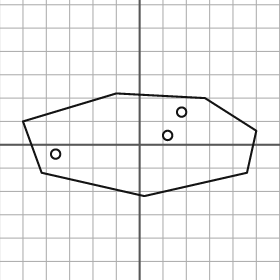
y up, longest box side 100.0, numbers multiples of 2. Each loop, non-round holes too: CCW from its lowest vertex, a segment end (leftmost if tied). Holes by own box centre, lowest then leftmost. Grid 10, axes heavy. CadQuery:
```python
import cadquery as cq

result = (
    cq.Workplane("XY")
    .moveTo(2.0, -22.0)
    .lineTo(46.0, -12.0)
    .lineTo(50.0, 6.0)
    .lineTo(28.0, 20.0)
    .lineTo(-10.0, 22.0)
    .lineTo(-50.0, 10.0)
    .lineTo(-42.0, -12.0)
    .close()
    .moveTo(-36.0, -4.0)
    .circle(2.0)
    .moveTo(12.0, 4.0)
    .circle(2.0)
    .moveTo(18.0, 14.0)
    .circle(2.0)
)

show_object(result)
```